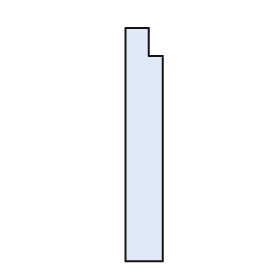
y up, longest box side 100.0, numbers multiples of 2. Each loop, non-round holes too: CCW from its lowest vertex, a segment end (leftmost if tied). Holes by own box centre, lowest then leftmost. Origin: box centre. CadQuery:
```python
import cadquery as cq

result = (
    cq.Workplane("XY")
    .moveTo(-8.0, -50.0)
    .lineTo(8.0, -50.0)
    .lineTo(8.0, 38.0)
    .lineTo(2.0, 38.0)
    .lineTo(2.0, 50.0)
    .lineTo(-8.0, 50.0)
    .close()
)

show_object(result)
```